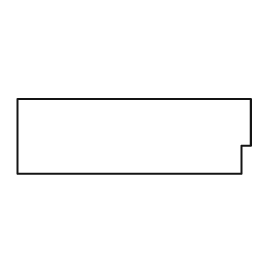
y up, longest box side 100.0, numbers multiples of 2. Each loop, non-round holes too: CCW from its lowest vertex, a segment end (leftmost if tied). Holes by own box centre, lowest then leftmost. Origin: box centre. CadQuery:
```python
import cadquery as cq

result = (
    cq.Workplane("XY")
    .moveTo(-50.0, -16.0)
    .lineTo(46.0, -16.0)
    .lineTo(46.0, -4.0)
    .lineTo(50.0, -4.0)
    .lineTo(50.0, 16.0)
    .lineTo(-50.0, 16.0)
    .close()
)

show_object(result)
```